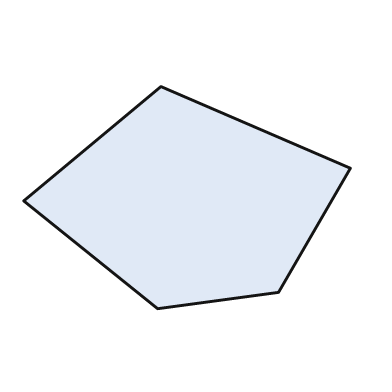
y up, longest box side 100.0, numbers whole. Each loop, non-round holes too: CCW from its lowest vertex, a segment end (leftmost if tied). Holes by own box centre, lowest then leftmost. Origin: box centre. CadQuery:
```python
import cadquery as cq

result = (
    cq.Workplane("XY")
    .moveTo(-9.0, -34.0)
    .lineTo(28.0, -29.0)
    .lineTo(50.0, 9.0)
    .lineTo(-8.0, 34.0)
    .lineTo(-50.0, -1.0)
    .close()
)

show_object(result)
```